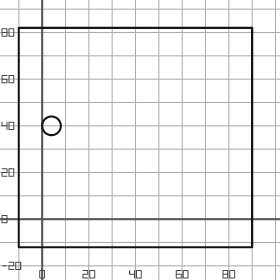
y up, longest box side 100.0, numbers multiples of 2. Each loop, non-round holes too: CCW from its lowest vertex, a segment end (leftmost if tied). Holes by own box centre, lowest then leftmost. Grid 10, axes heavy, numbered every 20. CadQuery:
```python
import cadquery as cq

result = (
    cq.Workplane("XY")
    .moveTo(-10.0, -12.0)
    .lineTo(90.0, -12.0)
    .lineTo(90.0, 82.0)
    .lineTo(-10.0, 82.0)
    .close()
    .moveTo(4.0, 40.0)
    .circle(4.0)
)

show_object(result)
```